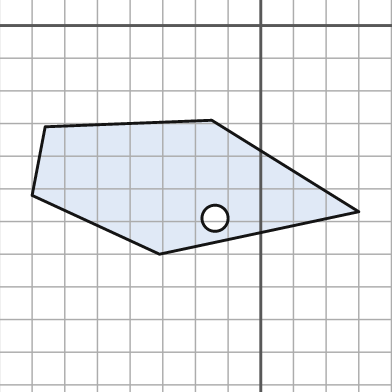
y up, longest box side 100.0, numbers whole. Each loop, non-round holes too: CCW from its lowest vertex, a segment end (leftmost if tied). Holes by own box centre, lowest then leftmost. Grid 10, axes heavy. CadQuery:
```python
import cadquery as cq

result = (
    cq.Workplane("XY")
    .moveTo(-31.0, -70.0)
    .lineTo(30.0, -57.0)
    .lineTo(-15.0, -29.0)
    .lineTo(-66.0, -31.0)
    .lineTo(-70.0, -52.0)
    .close()
    .moveTo(-14.0, -59.0)
    .circle(4.0)
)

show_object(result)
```